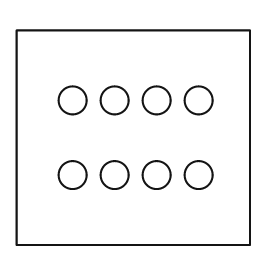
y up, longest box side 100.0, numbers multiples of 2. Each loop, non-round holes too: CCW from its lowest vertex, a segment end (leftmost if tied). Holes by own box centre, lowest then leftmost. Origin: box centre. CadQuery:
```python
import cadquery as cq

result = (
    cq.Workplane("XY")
    .moveTo(-50.0, -46.0)
    .lineTo(50.0, -46.0)
    .lineTo(50.0, 46.0)
    .lineTo(-50.0, 46.0)
    .close()
    .moveTo(-26.0, -16.0)
    .circle(6.0)
    .moveTo(-8.0, -16.0)
    .circle(6.0)
    .moveTo(10.0, -16.0)
    .circle(6.0)
    .moveTo(28.0, -16.0)
    .circle(6.0)
    .moveTo(-26.0, 16.0)
    .circle(6.0)
    .moveTo(-8.0, 16.0)
    .circle(6.0)
    .moveTo(10.0, 16.0)
    .circle(6.0)
    .moveTo(28.0, 16.0)
    .circle(6.0)
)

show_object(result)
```